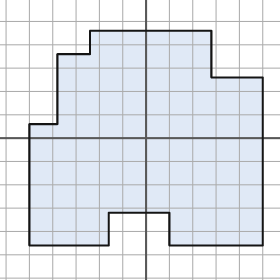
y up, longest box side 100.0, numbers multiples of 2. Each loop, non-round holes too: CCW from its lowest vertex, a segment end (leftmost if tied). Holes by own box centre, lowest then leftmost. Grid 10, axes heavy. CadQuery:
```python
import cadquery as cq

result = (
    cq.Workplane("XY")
    .moveTo(-50.0, -46.0)
    .lineTo(-16.0, -46.0)
    .lineTo(-16.0, -32.0)
    .lineTo(10.0, -32.0)
    .lineTo(10.0, -46.0)
    .lineTo(50.0, -46.0)
    .lineTo(50.0, 26.0)
    .lineTo(28.0, 26.0)
    .lineTo(28.0, 46.0)
    .lineTo(-24.0, 46.0)
    .lineTo(-24.0, 36.0)
    .lineTo(-38.0, 36.0)
    .lineTo(-38.0, 6.0)
    .lineTo(-50.0, 6.0)
    .close()
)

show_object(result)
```